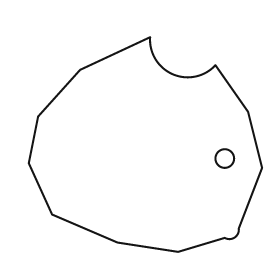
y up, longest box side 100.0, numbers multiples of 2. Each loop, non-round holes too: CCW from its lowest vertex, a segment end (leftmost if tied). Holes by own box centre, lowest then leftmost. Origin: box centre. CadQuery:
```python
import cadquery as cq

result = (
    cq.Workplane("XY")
    .moveTo(14.0, -46.0)
    .lineTo(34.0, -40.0)
    .threePointArc((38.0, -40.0), (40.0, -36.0))
    .lineTo(50.0, -10.0)
    .lineTo(44.0, 14.0)
    .lineTo(30.0, 34.0)
    .threePointArc((12.0, 30.0), (2.0, 46.0))
    .lineTo(-28.0, 32.0)
    .lineTo(-46.0, 12.0)
    .lineTo(-50.0, -8.0)
    .lineTo(-40.0, -30.0)
    .lineTo(-12.0, -42.0)
    .close()
    .moveTo(34.0, -6.0)
    .circle(4.0)
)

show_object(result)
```